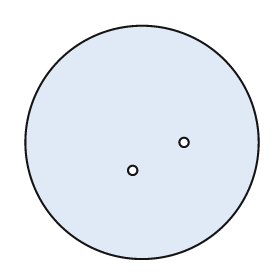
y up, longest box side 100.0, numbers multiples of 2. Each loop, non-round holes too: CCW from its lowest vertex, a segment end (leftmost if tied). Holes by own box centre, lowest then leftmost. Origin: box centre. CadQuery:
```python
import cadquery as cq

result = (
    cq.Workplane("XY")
    .moveTo(0.0, 0.0)
    .circle(50.0)
    .moveTo(-4.0, -12.0)
    .circle(2.0)
    .moveTo(18.0, 0.0)
    .circle(2.0)
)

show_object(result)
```